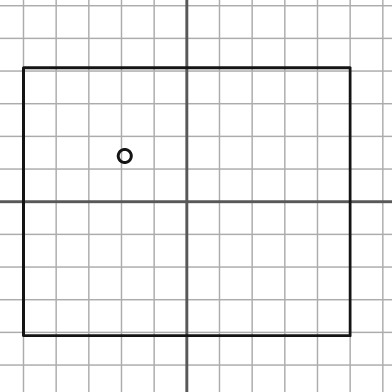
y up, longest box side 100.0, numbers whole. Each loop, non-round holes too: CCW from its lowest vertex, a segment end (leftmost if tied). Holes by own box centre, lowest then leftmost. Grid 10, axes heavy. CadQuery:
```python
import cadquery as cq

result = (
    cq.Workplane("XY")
    .moveTo(-50.0, -41.0)
    .lineTo(50.0, -41.0)
    .lineTo(50.0, 41.0)
    .lineTo(-50.0, 41.0)
    .close()
    .moveTo(-19.0, 14.0)
    .circle(2.0)
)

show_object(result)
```